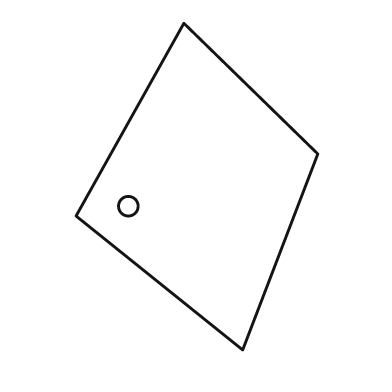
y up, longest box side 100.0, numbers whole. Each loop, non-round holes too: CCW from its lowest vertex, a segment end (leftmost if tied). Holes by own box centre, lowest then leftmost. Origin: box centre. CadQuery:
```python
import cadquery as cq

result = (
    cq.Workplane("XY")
    .moveTo(14.0, -50.0)
    .lineTo(37.0, 10.0)
    .lineTo(-4.0, 50.0)
    .lineTo(-37.0, -9.0)
    .close()
    .moveTo(-21.0, -6.0)
    .circle(3.0)
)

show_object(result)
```